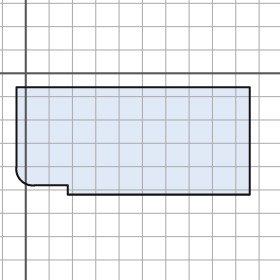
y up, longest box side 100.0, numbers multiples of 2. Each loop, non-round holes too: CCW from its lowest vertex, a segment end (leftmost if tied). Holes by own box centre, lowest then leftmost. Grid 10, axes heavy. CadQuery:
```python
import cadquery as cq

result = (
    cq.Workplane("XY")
    .moveTo(18.0, -52.0)
    .lineTo(96.0, -52.0)
    .lineTo(96.0, -6.0)
    .lineTo(-4.0, -6.0)
    .lineTo(-4.0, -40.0)
    .threePointArc((-2.0, -46.0), (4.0, -48.0))
    .lineTo(18.0, -48.0)
    .close()
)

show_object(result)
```